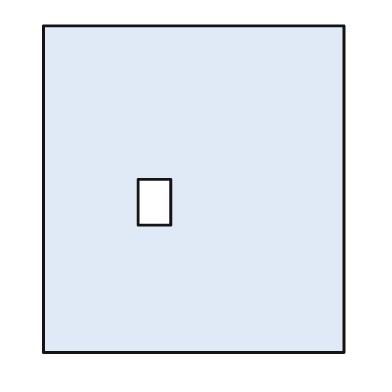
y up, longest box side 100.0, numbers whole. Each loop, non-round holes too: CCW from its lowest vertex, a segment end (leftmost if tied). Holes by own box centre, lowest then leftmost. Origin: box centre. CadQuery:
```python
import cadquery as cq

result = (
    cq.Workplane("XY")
    .moveTo(-46.0, -50.0)
    .lineTo(46.0, -50.0)
    .lineTo(46.0, 50.0)
    .lineTo(-46.0, 50.0)
    .close()
    .moveTo(-17.0, -11.0)
    .lineTo(-7.0, -11.0)
    .lineTo(-7.0, 3.0)
    .lineTo(-17.0, 3.0)
    .close()
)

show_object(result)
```